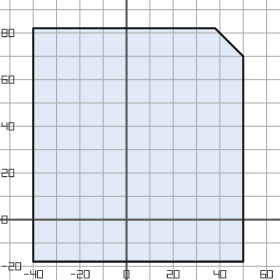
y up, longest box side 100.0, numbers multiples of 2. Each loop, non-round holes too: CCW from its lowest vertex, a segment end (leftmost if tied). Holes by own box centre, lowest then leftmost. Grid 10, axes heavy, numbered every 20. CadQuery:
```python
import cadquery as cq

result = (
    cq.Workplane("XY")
    .moveTo(-40.0, -18.0)
    .lineTo(50.0, -18.0)
    .lineTo(50.0, 70.0)
    .lineTo(38.0, 82.0)
    .lineTo(-40.0, 82.0)
    .close()
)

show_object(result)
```